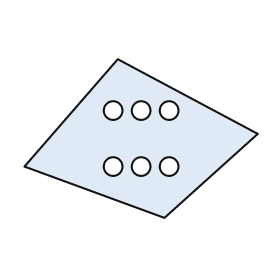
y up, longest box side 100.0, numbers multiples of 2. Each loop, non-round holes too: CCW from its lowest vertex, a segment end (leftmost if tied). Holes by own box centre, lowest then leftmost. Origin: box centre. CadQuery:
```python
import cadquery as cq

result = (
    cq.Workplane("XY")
    .moveTo(10.0, -34.0)
    .lineTo(50.0, 2.0)
    .lineTo(-10.0, 34.0)
    .lineTo(-50.0, -12.0)
    .close()
    .moveTo(-12.0, -12.0)
    .circle(4.0)
    .moveTo(0.0, -12.0)
    .circle(4.0)
    .moveTo(12.0, -12.0)
    .circle(4.0)
    .moveTo(-12.0, 12.0)
    .circle(4.0)
    .moveTo(0.0, 12.0)
    .circle(4.0)
    .moveTo(12.0, 12.0)
    .circle(4.0)
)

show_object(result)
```